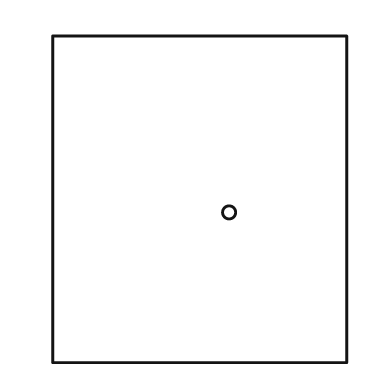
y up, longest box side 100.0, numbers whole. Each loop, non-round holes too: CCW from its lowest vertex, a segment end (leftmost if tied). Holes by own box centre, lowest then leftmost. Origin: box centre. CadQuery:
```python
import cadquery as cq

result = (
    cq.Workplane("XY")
    .moveTo(-45.0, -50.0)
    .lineTo(45.0, -50.0)
    .lineTo(45.0, 50.0)
    .lineTo(-45.0, 50.0)
    .close()
    .moveTo(9.0, -4.0)
    .circle(2.0)
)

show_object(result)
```